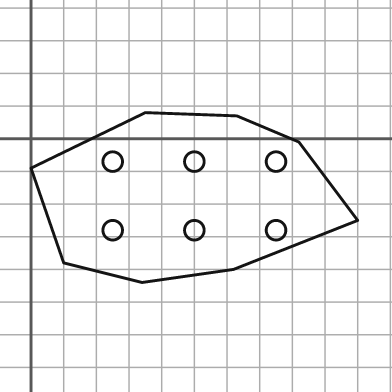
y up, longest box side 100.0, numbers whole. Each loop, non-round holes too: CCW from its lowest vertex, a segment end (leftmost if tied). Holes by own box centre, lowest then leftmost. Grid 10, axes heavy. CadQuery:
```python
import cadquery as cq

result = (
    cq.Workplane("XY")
    .moveTo(34.0, -44.0)
    .lineTo(62.0, -40.0)
    .lineTo(100.0, -25.0)
    .lineTo(82.0, -1.0)
    .lineTo(63.0, 7.0)
    .lineTo(35.0, 8.0)
    .lineTo(0.0, -9.0)
    .lineTo(10.0, -38.0)
    .close()
    .moveTo(25.0, -28.0)
    .circle(3.0)
    .moveTo(50.0, -28.0)
    .circle(3.0)
    .moveTo(75.0, -28.0)
    .circle(3.0)
    .moveTo(25.0, -7.0)
    .circle(3.0)
    .moveTo(50.0, -7.0)
    .circle(3.0)
    .moveTo(75.0, -7.0)
    .circle(3.0)
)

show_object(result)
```